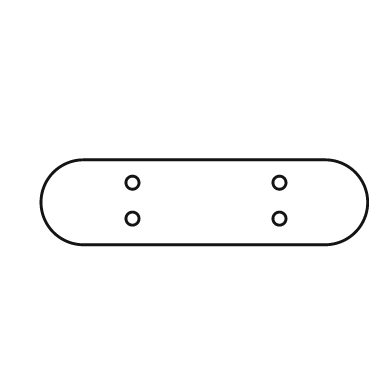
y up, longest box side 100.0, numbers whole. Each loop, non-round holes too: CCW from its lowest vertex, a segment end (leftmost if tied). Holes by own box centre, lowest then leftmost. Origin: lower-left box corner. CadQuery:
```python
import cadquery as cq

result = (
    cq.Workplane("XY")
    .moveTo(13.0, 0.0)
    .lineTo(87.0, 0.0)
    .threePointArc((100.0, 13.0), (87.0, 26.0))
    .lineTo(13.0, 26.0)
    .threePointArc((0.0, 13.0), (13.0, 0.0))
    .close()
    .moveTo(28.0, 8.0)
    .circle(2.0)
    .moveTo(73.0, 8.0)
    .circle(2.0)
    .moveTo(28.0, 19.0)
    .circle(2.0)
    .moveTo(73.0, 19.0)
    .circle(2.0)
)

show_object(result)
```